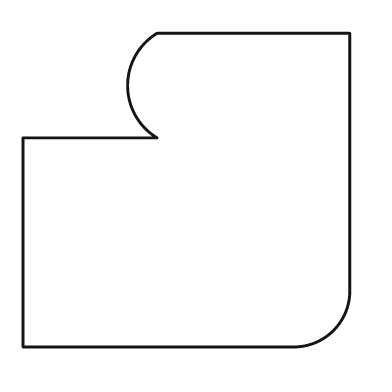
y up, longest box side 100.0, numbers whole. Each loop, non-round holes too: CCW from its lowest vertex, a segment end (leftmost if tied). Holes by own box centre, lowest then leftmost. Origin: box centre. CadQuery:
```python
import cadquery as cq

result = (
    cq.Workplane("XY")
    .moveTo(-50.0, -48.0)
    .lineTo(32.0, -48.0)
    .threePointArc((45.0, -43.0), (50.0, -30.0))
    .lineTo(50.0, 48.0)
    .lineTo(-9.0, 48.0)
    .threePointArc((-18.0, 32.0), (-9.0, 16.0))
    .lineTo(-50.0, 16.0)
    .close()
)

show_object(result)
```